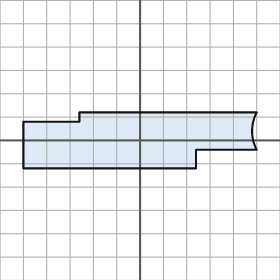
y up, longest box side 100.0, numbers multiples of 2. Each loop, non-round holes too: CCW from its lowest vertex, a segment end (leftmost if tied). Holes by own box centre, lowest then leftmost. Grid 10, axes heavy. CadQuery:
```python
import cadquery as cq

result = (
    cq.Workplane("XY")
    .moveTo(-50.0, -12.0)
    .lineTo(24.0, -12.0)
    .lineTo(24.0, -4.0)
    .lineTo(50.0, -4.0)
    .threePointArc((48.0, 4.0), (50.0, 12.0))
    .lineTo(-26.0, 12.0)
    .lineTo(-26.0, 8.0)
    .lineTo(-50.0, 8.0)
    .close()
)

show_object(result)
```